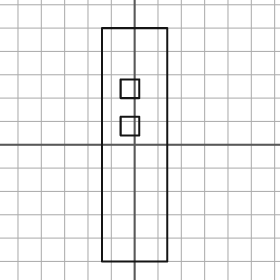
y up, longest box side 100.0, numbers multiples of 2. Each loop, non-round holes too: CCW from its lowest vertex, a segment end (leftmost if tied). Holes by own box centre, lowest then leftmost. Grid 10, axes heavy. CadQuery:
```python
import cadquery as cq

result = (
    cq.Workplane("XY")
    .moveTo(-14.0, -50.0)
    .lineTo(14.0, -50.0)
    .lineTo(14.0, 50.0)
    .lineTo(-14.0, 50.0)
    .close()
    .moveTo(-6.0, 4.0)
    .lineTo(2.0, 4.0)
    .lineTo(2.0, 12.0)
    .lineTo(-6.0, 12.0)
    .close()
    .moveTo(-6.0, 20.0)
    .lineTo(2.0, 20.0)
    .lineTo(2.0, 28.0)
    .lineTo(-6.0, 28.0)
    .close()
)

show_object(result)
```